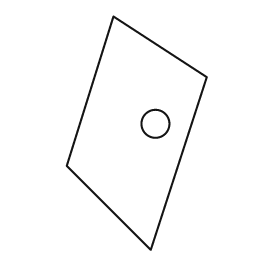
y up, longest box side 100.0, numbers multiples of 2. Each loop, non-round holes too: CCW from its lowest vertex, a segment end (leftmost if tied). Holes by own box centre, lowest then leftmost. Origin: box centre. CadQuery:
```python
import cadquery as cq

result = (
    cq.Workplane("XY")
    .moveTo(6.0, -50.0)
    .lineTo(30.0, 24.0)
    .lineTo(-10.0, 50.0)
    .lineTo(-30.0, -14.0)
    .close()
    .moveTo(8.0, 4.0)
    .circle(6.0)
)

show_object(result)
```